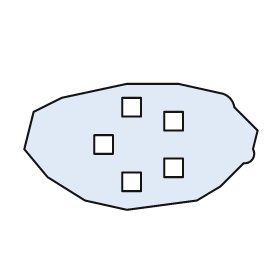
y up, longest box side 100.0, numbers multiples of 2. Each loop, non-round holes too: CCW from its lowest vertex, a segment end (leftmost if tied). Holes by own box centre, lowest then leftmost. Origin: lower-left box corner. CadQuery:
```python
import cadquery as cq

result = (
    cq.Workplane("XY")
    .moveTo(44.0, 0.0)
    .lineTo(74.0, 4.0)
    .lineTo(84.0, 10.0)
    .lineTo(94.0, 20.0)
    .threePointArc((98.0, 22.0), (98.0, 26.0))
    .lineTo(100.0, 34.0)
    .lineTo(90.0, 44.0)
    .threePointArc((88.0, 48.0), (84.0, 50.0))
    .lineTo(66.0, 54.0)
    .lineTo(44.0, 54.0)
    .lineTo(16.0, 48.0)
    .lineTo(4.0, 42.0)
    .lineTo(0.0, 26.0)
    .lineTo(10.0, 14.0)
    .lineTo(26.0, 4.0)
    .close()
    .moveTo(42.0, 8.0)
    .lineTo(50.0, 8.0)
    .lineTo(50.0, 16.0)
    .lineTo(42.0, 16.0)
    .close()
    .moveTo(60.0, 14.0)
    .lineTo(68.0, 14.0)
    .lineTo(68.0, 22.0)
    .lineTo(60.0, 22.0)
    .close()
    .moveTo(30.0, 24.0)
    .lineTo(38.0, 24.0)
    .lineTo(38.0, 32.0)
    .lineTo(30.0, 32.0)
    .close()
    .moveTo(60.0, 34.0)
    .lineTo(68.0, 34.0)
    .lineTo(68.0, 42.0)
    .lineTo(60.0, 42.0)
    .close()
    .moveTo(42.0, 40.0)
    .lineTo(50.0, 40.0)
    .lineTo(50.0, 48.0)
    .lineTo(42.0, 48.0)
    .close()
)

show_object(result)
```